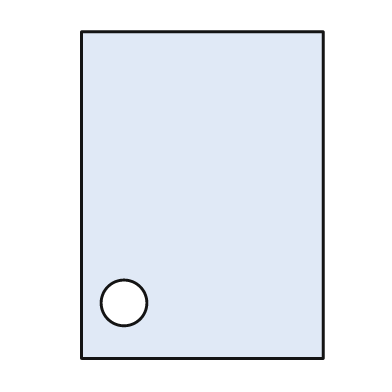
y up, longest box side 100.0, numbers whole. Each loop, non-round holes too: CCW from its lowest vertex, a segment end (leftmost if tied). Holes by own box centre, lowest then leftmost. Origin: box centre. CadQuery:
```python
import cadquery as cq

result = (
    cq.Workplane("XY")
    .moveTo(-37.0, -50.0)
    .lineTo(37.0, -50.0)
    .lineTo(37.0, 50.0)
    .lineTo(-37.0, 50.0)
    .close()
    .moveTo(-24.0, -33.0)
    .circle(7.0)
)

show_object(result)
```